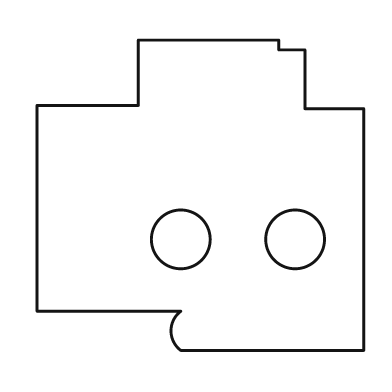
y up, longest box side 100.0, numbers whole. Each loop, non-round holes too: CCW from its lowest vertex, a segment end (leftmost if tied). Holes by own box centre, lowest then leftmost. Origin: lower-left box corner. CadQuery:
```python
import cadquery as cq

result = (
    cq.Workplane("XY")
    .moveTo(44.0, 0.0)
    .lineTo(100.0, 0.0)
    .lineTo(100.0, 74.0)
    .lineTo(82.0, 74.0)
    .lineTo(82.0, 92.0)
    .lineTo(74.0, 92.0)
    .lineTo(74.0, 95.0)
    .lineTo(31.0, 95.0)
    .lineTo(31.0, 75.0)
    .lineTo(0.0, 75.0)
    .lineTo(0.0, 12.0)
    .lineTo(44.0, 12.0)
    .threePointArc((41.0, 6.0), (44.0, 0.0))
    .close()
    .moveTo(44.0, 34.0)
    .circle(9.0)
    .moveTo(79.0, 34.0)
    .circle(9.0)
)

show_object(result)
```